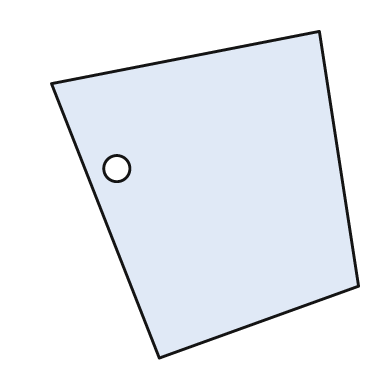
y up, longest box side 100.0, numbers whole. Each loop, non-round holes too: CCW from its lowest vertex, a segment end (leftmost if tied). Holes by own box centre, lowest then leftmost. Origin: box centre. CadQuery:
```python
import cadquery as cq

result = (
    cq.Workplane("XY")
    .moveTo(-14.0, -50.0)
    .lineTo(47.0, -28.0)
    .lineTo(35.0, 50.0)
    .lineTo(-47.0, 34.0)
    .close()
    .moveTo(-27.0, 8.0)
    .circle(4.0)
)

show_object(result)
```